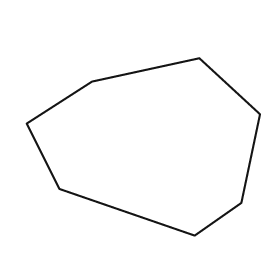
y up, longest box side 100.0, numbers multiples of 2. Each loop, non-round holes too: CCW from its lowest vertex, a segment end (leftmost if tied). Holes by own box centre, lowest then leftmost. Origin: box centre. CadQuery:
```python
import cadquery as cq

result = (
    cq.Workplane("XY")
    .moveTo(22.0, -38.0)
    .lineTo(42.0, -24.0)
    .lineTo(50.0, 14.0)
    .lineTo(24.0, 38.0)
    .lineTo(-22.0, 28.0)
    .lineTo(-50.0, 10.0)
    .lineTo(-36.0, -18.0)
    .close()
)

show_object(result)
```